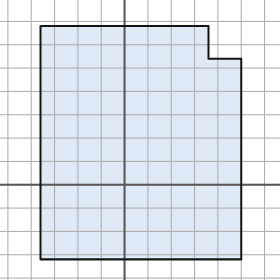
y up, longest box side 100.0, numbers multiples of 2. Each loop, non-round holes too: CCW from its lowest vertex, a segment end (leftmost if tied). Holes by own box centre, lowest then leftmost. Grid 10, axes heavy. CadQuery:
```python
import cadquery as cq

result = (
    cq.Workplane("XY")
    .moveTo(-36.0, -32.0)
    .lineTo(50.0, -32.0)
    .lineTo(50.0, 54.0)
    .lineTo(36.0, 54.0)
    .lineTo(36.0, 68.0)
    .lineTo(-36.0, 68.0)
    .close()
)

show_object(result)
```